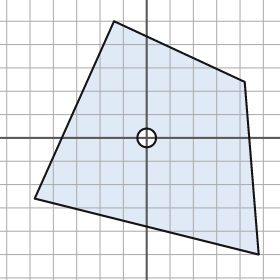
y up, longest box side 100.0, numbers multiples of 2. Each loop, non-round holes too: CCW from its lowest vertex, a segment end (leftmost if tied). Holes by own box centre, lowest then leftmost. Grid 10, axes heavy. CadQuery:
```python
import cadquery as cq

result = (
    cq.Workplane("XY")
    .moveTo(48.0, -50.0)
    .lineTo(42.0, 24.0)
    .lineTo(-14.0, 50.0)
    .lineTo(-48.0, -26.0)
    .close()
    .moveTo(0.0, 0.0)
    .circle(4.0)
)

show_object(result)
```